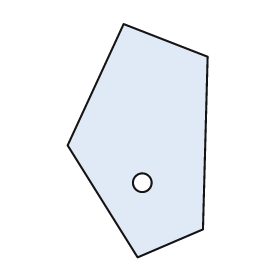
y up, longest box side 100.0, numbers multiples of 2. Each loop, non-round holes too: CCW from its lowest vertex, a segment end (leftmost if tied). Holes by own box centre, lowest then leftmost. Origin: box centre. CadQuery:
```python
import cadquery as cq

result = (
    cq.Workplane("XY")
    .moveTo(0.0, -50.0)
    .lineTo(28.0, -38.0)
    .lineTo(30.0, 36.0)
    .lineTo(-6.0, 50.0)
    .lineTo(-30.0, -2.0)
    .close()
    .moveTo(2.0, -18.0)
    .circle(4.0)
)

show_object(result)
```